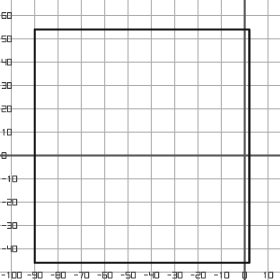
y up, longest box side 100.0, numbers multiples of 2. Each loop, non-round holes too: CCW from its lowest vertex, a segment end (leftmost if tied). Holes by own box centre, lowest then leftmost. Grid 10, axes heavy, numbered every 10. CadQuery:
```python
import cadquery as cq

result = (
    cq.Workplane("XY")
    .moveTo(-90.0, -46.0)
    .lineTo(2.0, -46.0)
    .lineTo(2.0, 54.0)
    .lineTo(-90.0, 54.0)
    .close()
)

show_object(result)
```